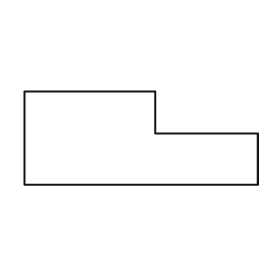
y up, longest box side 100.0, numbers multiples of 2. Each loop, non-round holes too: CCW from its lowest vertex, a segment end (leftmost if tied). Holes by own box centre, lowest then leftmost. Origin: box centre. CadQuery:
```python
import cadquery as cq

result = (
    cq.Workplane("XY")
    .moveTo(-50.0, -20.0)
    .lineTo(50.0, -20.0)
    .lineTo(50.0, 2.0)
    .lineTo(6.0, 2.0)
    .lineTo(6.0, 20.0)
    .lineTo(-50.0, 20.0)
    .close()
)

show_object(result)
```